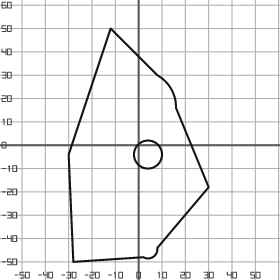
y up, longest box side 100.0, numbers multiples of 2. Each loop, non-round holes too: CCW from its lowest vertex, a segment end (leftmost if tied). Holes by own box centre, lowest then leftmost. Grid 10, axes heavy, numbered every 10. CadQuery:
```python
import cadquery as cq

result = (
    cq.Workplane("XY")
    .moveTo(-28.0, -50.0)
    .lineTo(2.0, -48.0)
    .threePointArc((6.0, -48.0), (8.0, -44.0))
    .lineTo(30.0, -18.0)
    .lineTo(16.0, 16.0)
    .threePointArc((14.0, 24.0), (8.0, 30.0))
    .lineTo(-12.0, 50.0)
    .lineTo(-30.0, -4.0)
    .close()
    .moveTo(4.0, -4.0)
    .circle(6.0)
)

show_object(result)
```